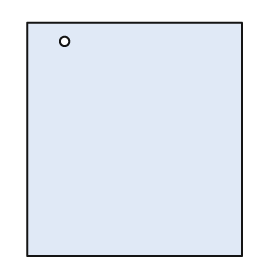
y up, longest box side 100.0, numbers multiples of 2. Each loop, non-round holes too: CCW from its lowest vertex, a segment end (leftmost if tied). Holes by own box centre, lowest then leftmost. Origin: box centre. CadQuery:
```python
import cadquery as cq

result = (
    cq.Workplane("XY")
    .moveTo(-46.0, -50.0)
    .lineTo(46.0, -50.0)
    .lineTo(46.0, 50.0)
    .lineTo(-46.0, 50.0)
    .close()
    .moveTo(-30.0, 42.0)
    .circle(2.0)
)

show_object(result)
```